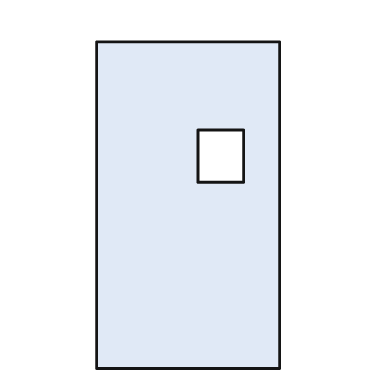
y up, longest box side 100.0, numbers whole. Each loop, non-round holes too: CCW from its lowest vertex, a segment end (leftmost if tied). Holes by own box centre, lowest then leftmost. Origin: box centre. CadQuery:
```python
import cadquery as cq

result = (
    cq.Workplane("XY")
    .moveTo(-28.0, -50.0)
    .lineTo(28.0, -50.0)
    .lineTo(28.0, 50.0)
    .lineTo(-28.0, 50.0)
    .close()
    .moveTo(3.0, 7.0)
    .lineTo(17.0, 7.0)
    .lineTo(17.0, 23.0)
    .lineTo(3.0, 23.0)
    .close()
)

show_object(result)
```